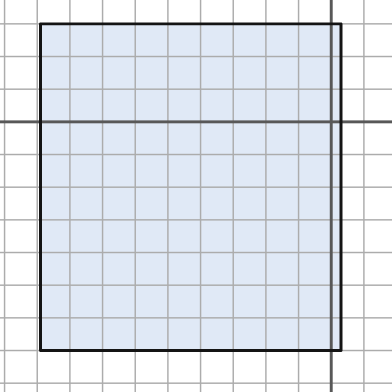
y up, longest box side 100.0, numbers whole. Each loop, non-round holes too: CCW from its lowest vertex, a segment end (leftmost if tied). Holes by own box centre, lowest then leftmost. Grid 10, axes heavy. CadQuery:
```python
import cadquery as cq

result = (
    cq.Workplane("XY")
    .moveTo(-89.0, -70.0)
    .lineTo(3.0, -70.0)
    .lineTo(3.0, 30.0)
    .lineTo(-89.0, 30.0)
    .close()
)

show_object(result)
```